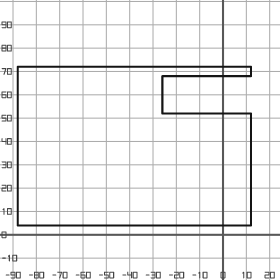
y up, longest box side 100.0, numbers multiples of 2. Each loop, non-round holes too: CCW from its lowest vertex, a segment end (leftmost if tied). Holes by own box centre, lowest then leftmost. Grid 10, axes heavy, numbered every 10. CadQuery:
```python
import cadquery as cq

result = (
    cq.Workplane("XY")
    .moveTo(-88.0, 4.0)
    .lineTo(12.0, 4.0)
    .lineTo(12.0, 52.0)
    .lineTo(-26.0, 52.0)
    .lineTo(-26.0, 68.0)
    .lineTo(12.0, 68.0)
    .lineTo(12.0, 72.0)
    .lineTo(-88.0, 72.0)
    .close()
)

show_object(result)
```